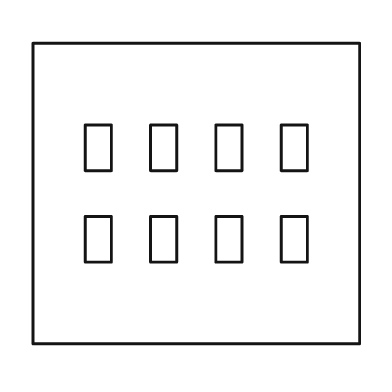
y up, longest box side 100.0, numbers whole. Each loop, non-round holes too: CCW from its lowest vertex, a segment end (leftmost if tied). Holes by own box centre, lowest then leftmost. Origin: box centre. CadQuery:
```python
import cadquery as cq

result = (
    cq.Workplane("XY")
    .moveTo(-50.0, -46.0)
    .lineTo(50.0, -46.0)
    .lineTo(50.0, 46.0)
    .lineTo(-50.0, 46.0)
    .close()
    .moveTo(-34.0, -21.0)
    .lineTo(-26.0, -21.0)
    .lineTo(-26.0, -7.0)
    .lineTo(-34.0, -7.0)
    .close()
    .moveTo(-14.0, -21.0)
    .lineTo(-6.0, -21.0)
    .lineTo(-6.0, -7.0)
    .lineTo(-14.0, -7.0)
    .close()
    .moveTo(6.0, -21.0)
    .lineTo(14.0, -21.0)
    .lineTo(14.0, -7.0)
    .lineTo(6.0, -7.0)
    .close()
    .moveTo(26.0, -21.0)
    .lineTo(34.0, -21.0)
    .lineTo(34.0, -7.0)
    .lineTo(26.0, -7.0)
    .close()
    .moveTo(-34.0, 7.0)
    .lineTo(-26.0, 7.0)
    .lineTo(-26.0, 21.0)
    .lineTo(-34.0, 21.0)
    .close()
    .moveTo(-14.0, 7.0)
    .lineTo(-6.0, 7.0)
    .lineTo(-6.0, 21.0)
    .lineTo(-14.0, 21.0)
    .close()
    .moveTo(6.0, 7.0)
    .lineTo(14.0, 7.0)
    .lineTo(14.0, 21.0)
    .lineTo(6.0, 21.0)
    .close()
    .moveTo(26.0, 7.0)
    .lineTo(34.0, 7.0)
    .lineTo(34.0, 21.0)
    .lineTo(26.0, 21.0)
    .close()
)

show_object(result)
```